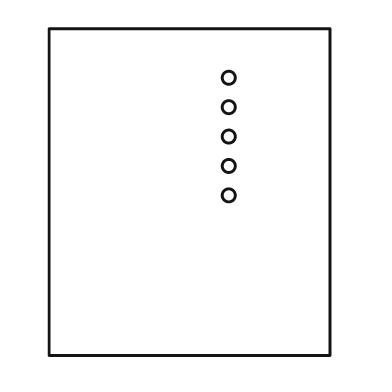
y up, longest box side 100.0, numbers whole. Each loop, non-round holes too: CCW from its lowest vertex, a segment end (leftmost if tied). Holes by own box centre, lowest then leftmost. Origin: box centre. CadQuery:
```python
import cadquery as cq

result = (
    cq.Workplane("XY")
    .moveTo(-43.0, -50.0)
    .lineTo(43.0, -50.0)
    .lineTo(43.0, 50.0)
    .lineTo(-43.0, 50.0)
    .close()
    .moveTo(12.0, -1.0)
    .circle(2.0)
    .moveTo(12.0, 8.0)
    .circle(2.0)
    .moveTo(12.0, 17.0)
    .circle(2.0)
    .moveTo(12.0, 26.0)
    .circle(2.0)
    .moveTo(12.0, 35.0)
    .circle(2.0)
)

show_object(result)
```